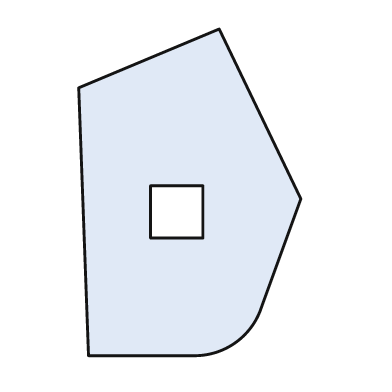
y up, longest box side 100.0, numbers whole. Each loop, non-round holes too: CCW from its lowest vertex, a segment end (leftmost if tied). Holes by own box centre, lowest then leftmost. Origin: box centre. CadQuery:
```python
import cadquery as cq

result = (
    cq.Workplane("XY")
    .moveTo(-31.0, -50.0)
    .lineTo(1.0, -50.0)
    .threePointArc((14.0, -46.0), (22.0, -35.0))
    .lineTo(34.0, -2.0)
    .lineTo(9.0, 50.0)
    .lineTo(-34.0, 32.0)
    .close()
    .moveTo(-12.0, -14.0)
    .lineTo(4.0, -14.0)
    .lineTo(4.0, 2.0)
    .lineTo(-12.0, 2.0)
    .close()
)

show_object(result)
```